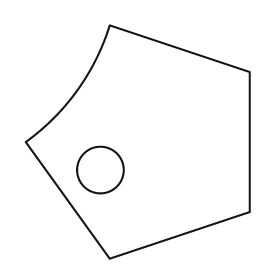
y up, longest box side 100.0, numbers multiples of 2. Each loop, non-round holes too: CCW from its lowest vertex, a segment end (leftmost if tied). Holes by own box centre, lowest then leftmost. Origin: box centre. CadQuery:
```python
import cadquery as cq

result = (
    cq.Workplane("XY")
    .moveTo(-12.0, -50.0)
    .lineTo(48.0, -30.0)
    .lineTo(48.0, 30.0)
    .lineTo(-12.0, 50.0)
    .threePointArc((-26.0, 22.0), (-48.0, 0.0))
    .close()
    .moveTo(-16.0, -12.0)
    .circle(10.0)
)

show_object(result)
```